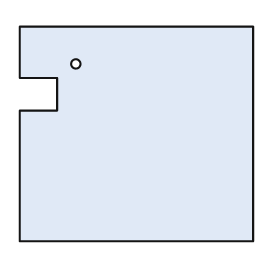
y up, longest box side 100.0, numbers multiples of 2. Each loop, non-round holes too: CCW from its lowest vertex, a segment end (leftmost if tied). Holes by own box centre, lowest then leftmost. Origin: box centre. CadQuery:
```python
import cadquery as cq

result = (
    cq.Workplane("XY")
    .moveTo(-50.0, -46.0)
    .lineTo(50.0, -46.0)
    .lineTo(50.0, 46.0)
    .lineTo(-50.0, 46.0)
    .lineTo(-50.0, 24.0)
    .lineTo(-34.0, 24.0)
    .lineTo(-34.0, 10.0)
    .lineTo(-50.0, 10.0)
    .close()
    .moveTo(-26.0, 30.0)
    .circle(2.0)
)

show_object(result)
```